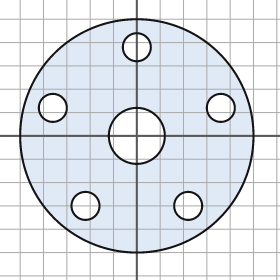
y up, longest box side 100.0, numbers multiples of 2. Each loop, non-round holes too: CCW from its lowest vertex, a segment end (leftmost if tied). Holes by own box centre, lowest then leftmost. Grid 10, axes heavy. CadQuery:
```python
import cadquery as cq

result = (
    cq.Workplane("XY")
    .moveTo(0.0, 0.0)
    .circle(50.0)
    .moveTo(-22.0, -30.0)
    .circle(6.0)
    .moveTo(22.0, -30.0)
    .circle(6.0)
    .moveTo(0.0, 0.0)
    .circle(12.0)
    .moveTo(-36.0, 12.0)
    .circle(6.0)
    .moveTo(36.0, 12.0)
    .circle(6.0)
    .moveTo(0.0, 38.0)
    .circle(6.0)
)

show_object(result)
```